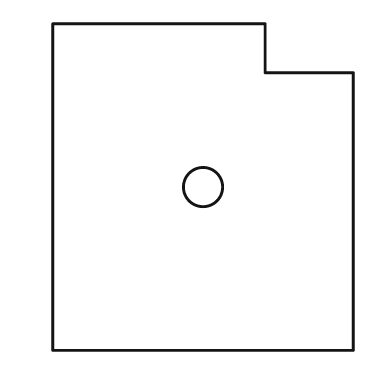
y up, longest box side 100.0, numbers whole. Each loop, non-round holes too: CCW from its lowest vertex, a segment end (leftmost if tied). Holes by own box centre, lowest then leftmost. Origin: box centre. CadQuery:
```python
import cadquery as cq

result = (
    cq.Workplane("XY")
    .moveTo(-46.0, -50.0)
    .lineTo(46.0, -50.0)
    .lineTo(46.0, 35.0)
    .lineTo(19.0, 35.0)
    .lineTo(19.0, 50.0)
    .lineTo(-46.0, 50.0)
    .close()
    .moveTo(0.0, 0.0)
    .circle(6.0)
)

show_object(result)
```